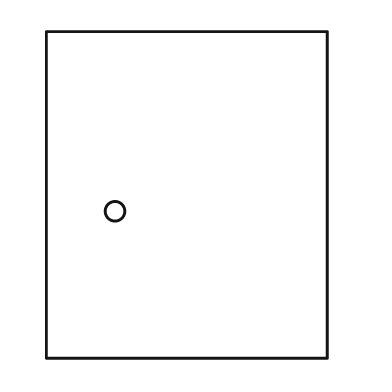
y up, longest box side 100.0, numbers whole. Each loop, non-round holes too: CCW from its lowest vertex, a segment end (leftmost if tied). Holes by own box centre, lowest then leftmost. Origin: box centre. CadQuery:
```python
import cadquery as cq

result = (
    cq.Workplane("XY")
    .moveTo(-43.0, -50.0)
    .lineTo(43.0, -50.0)
    .lineTo(43.0, 50.0)
    .lineTo(-43.0, 50.0)
    .close()
    .moveTo(-22.0, -5.0)
    .circle(3.0)
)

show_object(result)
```